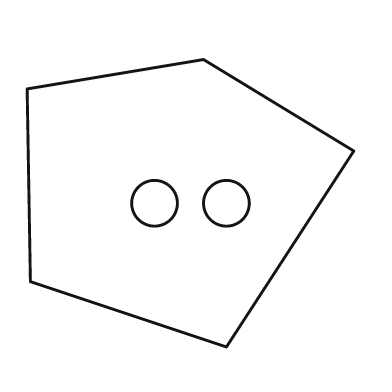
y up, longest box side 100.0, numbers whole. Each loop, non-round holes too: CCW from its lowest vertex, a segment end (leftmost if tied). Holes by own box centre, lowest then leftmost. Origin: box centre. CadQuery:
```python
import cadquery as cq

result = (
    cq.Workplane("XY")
    .moveTo(11.0, -44.0)
    .lineTo(50.0, 16.0)
    .lineTo(4.0, 44.0)
    .lineTo(-50.0, 35.0)
    .lineTo(-49.0, -24.0)
    .close()
    .moveTo(-11.0, 0.0)
    .circle(7.0)
    .moveTo(11.0, 0.0)
    .circle(7.0)
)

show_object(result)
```